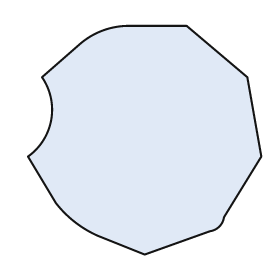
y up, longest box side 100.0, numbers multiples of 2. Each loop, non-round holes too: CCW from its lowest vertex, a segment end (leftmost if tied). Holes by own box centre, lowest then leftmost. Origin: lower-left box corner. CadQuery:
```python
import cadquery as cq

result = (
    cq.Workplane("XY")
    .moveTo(50.0, 0.0)
    .lineTo(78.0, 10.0)
    .threePointArc((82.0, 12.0), (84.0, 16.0))
    .lineTo(100.0, 42.0)
    .lineTo(94.0, 76.0)
    .lineTo(68.0, 98.0)
    .lineTo(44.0, 98.0)
    .threePointArc((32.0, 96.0), (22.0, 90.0))
    .lineTo(6.0, 76.0)
    .threePointArc((10.0, 58.0), (0.0, 42.0))
    .lineTo(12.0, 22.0)
    .threePointArc((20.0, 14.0), (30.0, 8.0))
    .close()
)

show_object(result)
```